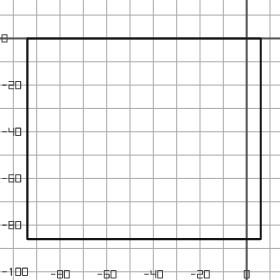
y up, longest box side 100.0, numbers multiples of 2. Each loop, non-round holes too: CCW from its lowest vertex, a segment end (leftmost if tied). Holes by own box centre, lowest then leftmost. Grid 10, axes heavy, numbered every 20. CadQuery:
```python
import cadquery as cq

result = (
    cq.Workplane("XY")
    .moveTo(-94.0, -86.0)
    .lineTo(6.0, -86.0)
    .lineTo(6.0, 0.0)
    .lineTo(-94.0, 0.0)
    .close()
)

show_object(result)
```